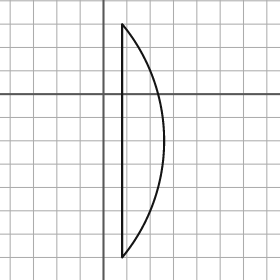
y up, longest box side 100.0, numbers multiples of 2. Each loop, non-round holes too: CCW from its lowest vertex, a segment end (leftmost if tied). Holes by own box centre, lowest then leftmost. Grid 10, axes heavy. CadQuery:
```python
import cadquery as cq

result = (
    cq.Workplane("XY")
    .moveTo(8.0, -70.0)
    .threePointArc((26.0, -20.0), (8.0, 30.0))
    .close()
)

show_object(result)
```